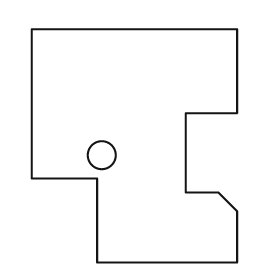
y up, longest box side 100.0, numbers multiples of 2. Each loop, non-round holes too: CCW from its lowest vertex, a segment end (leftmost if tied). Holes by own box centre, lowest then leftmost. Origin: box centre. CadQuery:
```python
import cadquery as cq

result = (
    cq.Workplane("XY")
    .moveTo(-16.0, -50.0)
    .lineTo(44.0, -50.0)
    .lineTo(44.0, -28.0)
    .lineTo(36.0, -20.0)
    .lineTo(22.0, -20.0)
    .lineTo(22.0, 14.0)
    .lineTo(44.0, 14.0)
    .lineTo(44.0, 50.0)
    .lineTo(-44.0, 50.0)
    .lineTo(-44.0, -14.0)
    .lineTo(-16.0, -14.0)
    .close()
    .moveTo(-14.0, -4.0)
    .circle(6.0)
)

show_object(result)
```